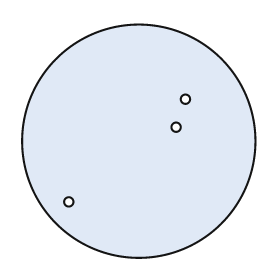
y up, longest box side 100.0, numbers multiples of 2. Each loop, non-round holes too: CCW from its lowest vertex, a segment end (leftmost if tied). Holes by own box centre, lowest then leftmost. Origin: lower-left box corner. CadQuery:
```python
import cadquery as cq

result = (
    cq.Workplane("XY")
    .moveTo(50.0, 50.0)
    .circle(50.0)
    .moveTo(20.0, 24.0)
    .circle(2.0)
    .moveTo(66.0, 56.0)
    .circle(2.0)
    .moveTo(70.0, 68.0)
    .circle(2.0)
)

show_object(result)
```